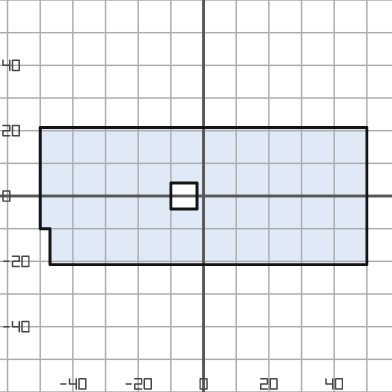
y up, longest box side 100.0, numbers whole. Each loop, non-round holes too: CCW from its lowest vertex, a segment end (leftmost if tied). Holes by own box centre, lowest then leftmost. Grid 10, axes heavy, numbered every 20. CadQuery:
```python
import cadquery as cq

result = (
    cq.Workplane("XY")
    .moveTo(-47.0, -21.0)
    .lineTo(50.0, -21.0)
    .lineTo(50.0, 21.0)
    .lineTo(-50.0, 21.0)
    .lineTo(-50.0, -10.0)
    .lineTo(-47.0, -10.0)
    .close()
    .moveTo(-10.0, -4.0)
    .lineTo(-2.0, -4.0)
    .lineTo(-2.0, 4.0)
    .lineTo(-10.0, 4.0)
    .close()
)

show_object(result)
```